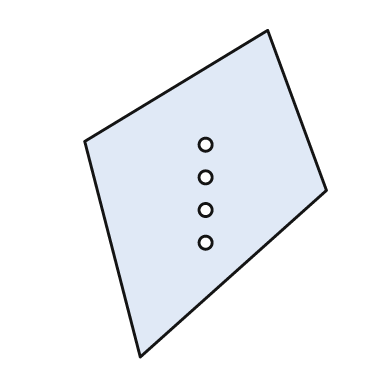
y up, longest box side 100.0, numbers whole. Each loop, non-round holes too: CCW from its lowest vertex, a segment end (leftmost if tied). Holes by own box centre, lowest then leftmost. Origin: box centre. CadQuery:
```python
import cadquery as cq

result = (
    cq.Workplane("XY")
    .moveTo(-20.0, -50.0)
    .lineTo(37.0, 1.0)
    .lineTo(19.0, 50.0)
    .lineTo(-37.0, 16.0)
    .close()
    .moveTo(0.0, -15.0)
    .circle(2.0)
    .moveTo(0.0, -5.0)
    .circle(2.0)
    .moveTo(0.0, 5.0)
    .circle(2.0)
    .moveTo(0.0, 15.0)
    .circle(2.0)
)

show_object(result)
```